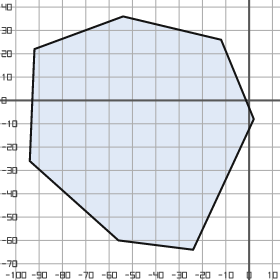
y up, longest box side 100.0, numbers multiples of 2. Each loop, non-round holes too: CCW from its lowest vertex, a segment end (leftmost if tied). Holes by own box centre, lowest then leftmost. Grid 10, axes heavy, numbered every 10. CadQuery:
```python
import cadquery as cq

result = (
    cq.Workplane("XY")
    .moveTo(-24.0, -64.0)
    .lineTo(2.0, -8.0)
    .lineTo(-12.0, 26.0)
    .lineTo(-54.0, 36.0)
    .lineTo(-92.0, 22.0)
    .lineTo(-94.0, -26.0)
    .lineTo(-56.0, -60.0)
    .close()
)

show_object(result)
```